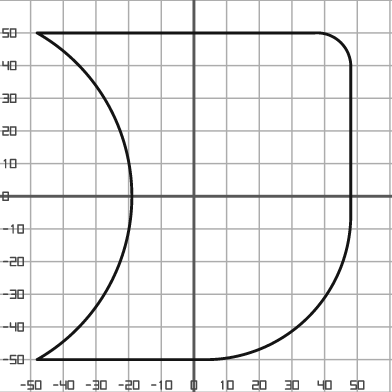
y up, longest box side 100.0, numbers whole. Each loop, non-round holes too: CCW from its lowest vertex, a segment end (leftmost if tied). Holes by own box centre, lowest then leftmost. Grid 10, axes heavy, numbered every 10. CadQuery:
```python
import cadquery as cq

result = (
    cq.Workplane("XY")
    .moveTo(-48.0, -50.0)
    .lineTo(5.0, -50.0)
    .threePointArc((35.0, -37.0), (48.0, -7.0))
    .lineTo(48.0, 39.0)
    .threePointArc((45.0, 47.0), (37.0, 50.0))
    .lineTo(-48.0, 50.0)
    .threePointArc((-19.0, 0.0), (-48.0, -50.0))
    .close()
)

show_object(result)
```